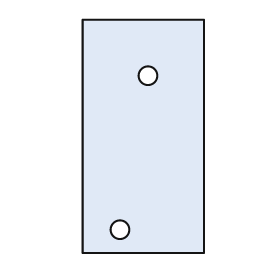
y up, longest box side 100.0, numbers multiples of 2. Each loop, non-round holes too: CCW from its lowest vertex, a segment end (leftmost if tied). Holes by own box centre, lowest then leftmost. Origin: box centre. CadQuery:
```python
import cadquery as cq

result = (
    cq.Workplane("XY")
    .moveTo(-26.0, -50.0)
    .lineTo(26.0, -50.0)
    .lineTo(26.0, 50.0)
    .lineTo(-26.0, 50.0)
    .close()
    .moveTo(-10.0, -40.0)
    .circle(4.0)
    .moveTo(2.0, 26.0)
    .circle(4.0)
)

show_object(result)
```